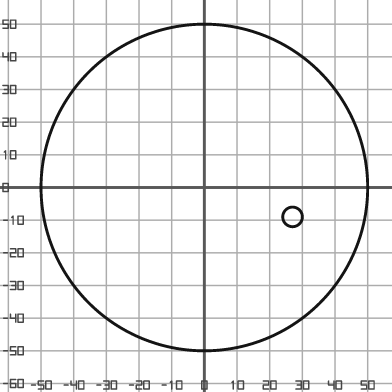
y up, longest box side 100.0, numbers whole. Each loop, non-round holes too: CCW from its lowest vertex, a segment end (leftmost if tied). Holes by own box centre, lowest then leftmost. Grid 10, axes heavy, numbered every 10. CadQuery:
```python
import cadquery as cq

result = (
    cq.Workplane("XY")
    .moveTo(0.0, 0.0)
    .circle(50.0)
    .moveTo(27.0, -9.0)
    .circle(3.0)
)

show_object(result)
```